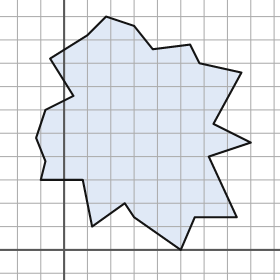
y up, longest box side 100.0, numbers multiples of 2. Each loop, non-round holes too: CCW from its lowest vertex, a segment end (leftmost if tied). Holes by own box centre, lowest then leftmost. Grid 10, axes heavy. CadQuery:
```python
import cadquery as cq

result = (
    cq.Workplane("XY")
    .moveTo(50.0, 0.0)
    .lineTo(56.0, 14.0)
    .lineTo(74.0, 14.0)
    .lineTo(62.0, 40.0)
    .lineTo(80.0, 46.0)
    .lineTo(64.0, 54.0)
    .lineTo(76.0, 76.0)
    .lineTo(58.0, 80.0)
    .lineTo(54.0, 88.0)
    .lineTo(38.0, 86.0)
    .lineTo(30.0, 96.0)
    .lineTo(18.0, 100.0)
    .lineTo(10.0, 92.0)
    .lineTo(-6.0, 82.0)
    .lineTo(4.0, 66.0)
    .lineTo(-8.0, 60.0)
    .lineTo(-12.0, 48.0)
    .lineTo(-8.0, 38.0)
    .lineTo(-10.0, 30.0)
    .lineTo(8.0, 30.0)
    .lineTo(12.0, 10.0)
    .lineTo(26.0, 20.0)
    .lineTo(30.0, 14.0)
    .close()
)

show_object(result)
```